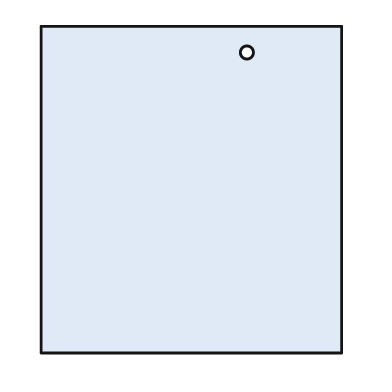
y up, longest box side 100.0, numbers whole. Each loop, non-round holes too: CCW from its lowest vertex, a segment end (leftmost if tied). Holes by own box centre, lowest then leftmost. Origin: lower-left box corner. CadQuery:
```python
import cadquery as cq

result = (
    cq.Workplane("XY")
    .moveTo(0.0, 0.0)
    .lineTo(92.0, 0.0)
    .lineTo(92.0, 100.0)
    .lineTo(0.0, 100.0)
    .close()
    .moveTo(63.0, 92.0)
    .circle(2.0)
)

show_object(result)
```